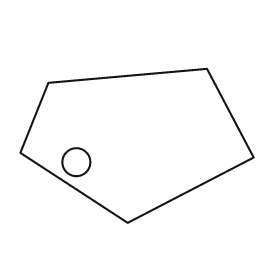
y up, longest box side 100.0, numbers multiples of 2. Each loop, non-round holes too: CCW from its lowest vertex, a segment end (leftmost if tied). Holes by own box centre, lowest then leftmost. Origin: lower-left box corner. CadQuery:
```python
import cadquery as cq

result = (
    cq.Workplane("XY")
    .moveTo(46.0, 0.0)
    .lineTo(100.0, 28.0)
    .lineTo(80.0, 66.0)
    .lineTo(12.0, 60.0)
    .lineTo(0.0, 30.0)
    .close()
    .moveTo(24.0, 26.0)
    .circle(6.0)
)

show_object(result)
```